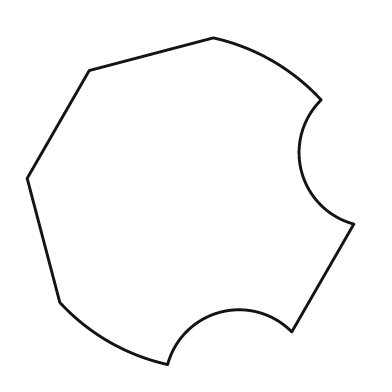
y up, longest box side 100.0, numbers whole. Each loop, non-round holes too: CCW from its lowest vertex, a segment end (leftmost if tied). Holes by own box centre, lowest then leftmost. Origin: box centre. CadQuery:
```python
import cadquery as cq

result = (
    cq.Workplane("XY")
    .moveTo(-7.0, -50.0)
    .threePointArc((9.0, -34.0), (31.0, -40.0))
    .lineTo(50.0, -7.0)
    .threePointArc((34.0, 9.0), (40.0, 31.0))
    .threePointArc((25.0, 43.0), (7.0, 50.0))
    .lineTo(-31.0, 40.0)
    .lineTo(-50.0, 7.0)
    .lineTo(-40.0, -31.0)
    .threePointArc((-25.0, -43.0), (-7.0, -50.0))
    .close()
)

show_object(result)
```